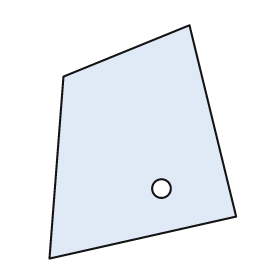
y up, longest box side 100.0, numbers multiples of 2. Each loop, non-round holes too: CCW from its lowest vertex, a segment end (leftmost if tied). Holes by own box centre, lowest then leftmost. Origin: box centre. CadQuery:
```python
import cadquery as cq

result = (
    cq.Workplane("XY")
    .moveTo(-40.0, -50.0)
    .lineTo(40.0, -32.0)
    .lineTo(20.0, 50.0)
    .lineTo(-34.0, 28.0)
    .close()
    .moveTo(8.0, -20.0)
    .circle(4.0)
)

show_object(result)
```